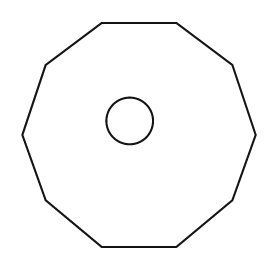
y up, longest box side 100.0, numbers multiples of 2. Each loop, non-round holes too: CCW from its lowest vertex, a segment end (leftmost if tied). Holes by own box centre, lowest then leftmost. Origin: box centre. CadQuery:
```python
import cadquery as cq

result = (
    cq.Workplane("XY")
    .moveTo(-16.0, -48.0)
    .lineTo(16.0, -48.0)
    .lineTo(40.0, -28.0)
    .lineTo(50.0, 0.0)
    .lineTo(40.0, 30.0)
    .lineTo(16.0, 48.0)
    .lineTo(-16.0, 48.0)
    .lineTo(-40.0, 30.0)
    .lineTo(-50.0, 0.0)
    .lineTo(-40.0, -28.0)
    .close()
    .moveTo(-4.0, 6.0)
    .circle(10.0)
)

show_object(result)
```